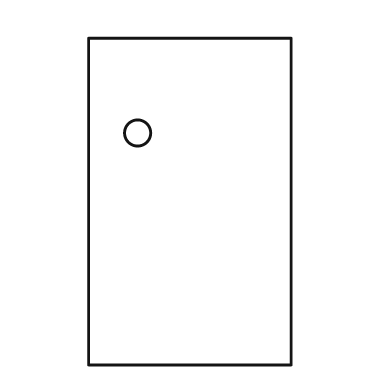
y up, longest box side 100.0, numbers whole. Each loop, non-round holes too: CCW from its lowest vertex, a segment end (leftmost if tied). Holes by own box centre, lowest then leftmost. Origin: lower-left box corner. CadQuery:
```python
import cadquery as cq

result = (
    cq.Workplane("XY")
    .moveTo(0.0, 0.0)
    .lineTo(62.0, 0.0)
    .lineTo(62.0, 100.0)
    .lineTo(0.0, 100.0)
    .close()
    .moveTo(15.0, 71.0)
    .circle(4.0)
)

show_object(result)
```